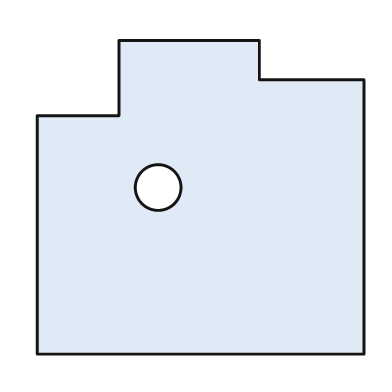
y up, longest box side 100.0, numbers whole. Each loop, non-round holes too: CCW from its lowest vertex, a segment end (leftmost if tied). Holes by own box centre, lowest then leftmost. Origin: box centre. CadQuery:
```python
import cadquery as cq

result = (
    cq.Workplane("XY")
    .moveTo(-50.0, -48.0)
    .lineTo(50.0, -48.0)
    .lineTo(50.0, 36.0)
    .lineTo(18.0, 36.0)
    .lineTo(18.0, 48.0)
    .lineTo(-25.0, 48.0)
    .lineTo(-25.0, 25.0)
    .lineTo(-50.0, 25.0)
    .close()
    .moveTo(-13.0, 3.0)
    .circle(7.0)
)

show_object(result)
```